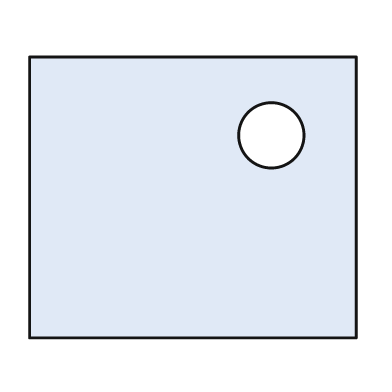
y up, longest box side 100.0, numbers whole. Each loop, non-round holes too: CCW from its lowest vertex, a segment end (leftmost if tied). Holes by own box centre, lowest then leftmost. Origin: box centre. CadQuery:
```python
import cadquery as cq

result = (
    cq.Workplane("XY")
    .moveTo(-50.0, -43.0)
    .lineTo(50.0, -43.0)
    .lineTo(50.0, 43.0)
    .lineTo(-50.0, 43.0)
    .close()
    .moveTo(24.0, 19.0)
    .circle(10.0)
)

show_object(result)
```